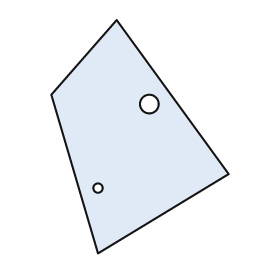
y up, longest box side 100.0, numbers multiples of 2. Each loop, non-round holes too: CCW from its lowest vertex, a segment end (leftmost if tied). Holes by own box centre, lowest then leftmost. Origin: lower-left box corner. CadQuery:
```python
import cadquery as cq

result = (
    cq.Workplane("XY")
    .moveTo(20.0, 0.0)
    .lineTo(76.0, 34.0)
    .lineTo(28.0, 100.0)
    .lineTo(0.0, 68.0)
    .close()
    .moveTo(20.0, 28.0)
    .circle(2.0)
    .moveTo(42.0, 64.0)
    .circle(4.0)
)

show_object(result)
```